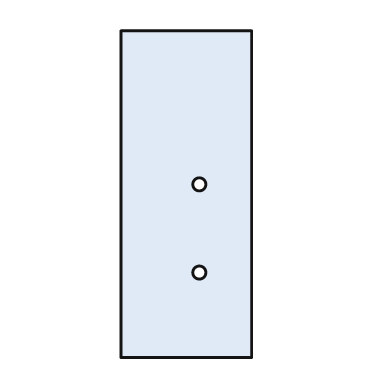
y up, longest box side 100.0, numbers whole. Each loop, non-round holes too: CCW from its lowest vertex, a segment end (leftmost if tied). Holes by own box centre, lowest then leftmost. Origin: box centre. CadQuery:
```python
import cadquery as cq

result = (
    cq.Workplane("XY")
    .moveTo(-20.0, -50.0)
    .lineTo(20.0, -50.0)
    .lineTo(20.0, 50.0)
    .lineTo(-20.0, 50.0)
    .close()
    .moveTo(4.0, -24.0)
    .circle(2.0)
    .moveTo(4.0, 3.0)
    .circle(2.0)
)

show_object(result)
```